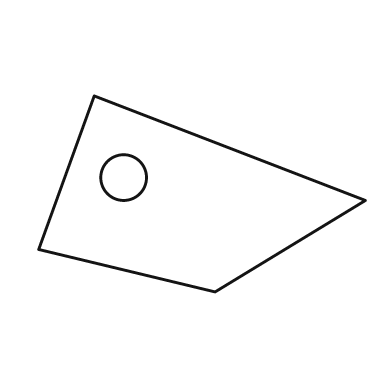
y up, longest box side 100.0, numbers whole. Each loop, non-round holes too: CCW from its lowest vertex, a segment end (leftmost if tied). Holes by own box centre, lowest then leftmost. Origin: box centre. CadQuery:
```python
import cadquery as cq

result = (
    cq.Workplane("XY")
    .moveTo(4.0, -30.0)
    .lineTo(50.0, -2.0)
    .lineTo(-33.0, 30.0)
    .lineTo(-50.0, -17.0)
    .close()
    .moveTo(-24.0, 5.0)
    .circle(7.0)
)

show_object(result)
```